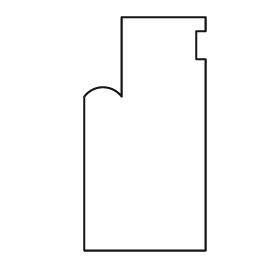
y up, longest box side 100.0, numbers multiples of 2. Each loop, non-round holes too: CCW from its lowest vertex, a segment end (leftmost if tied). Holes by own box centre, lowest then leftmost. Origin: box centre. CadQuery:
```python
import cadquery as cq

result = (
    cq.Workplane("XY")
    .moveTo(-26.0, -50.0)
    .lineTo(26.0, -50.0)
    .lineTo(26.0, 32.0)
    .lineTo(22.0, 32.0)
    .lineTo(22.0, 44.0)
    .lineTo(26.0, 44.0)
    .lineTo(26.0, 50.0)
    .lineTo(-10.0, 50.0)
    .lineTo(-10.0, 16.0)
    .threePointArc((-18.0, 20.0), (-26.0, 16.0))
    .close()
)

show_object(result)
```